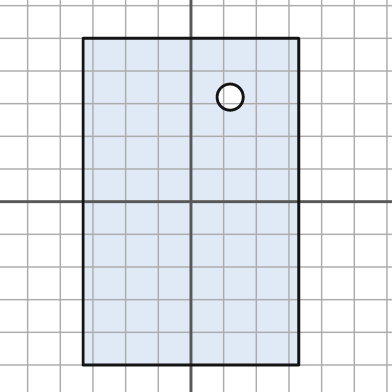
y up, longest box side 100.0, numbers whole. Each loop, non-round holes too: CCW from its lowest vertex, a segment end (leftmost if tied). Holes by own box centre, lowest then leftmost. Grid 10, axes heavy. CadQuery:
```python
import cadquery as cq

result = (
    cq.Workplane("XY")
    .moveTo(-33.0, -50.0)
    .lineTo(33.0, -50.0)
    .lineTo(33.0, 50.0)
    .lineTo(-33.0, 50.0)
    .close()
    .moveTo(12.0, 32.0)
    .circle(4.0)
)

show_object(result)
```